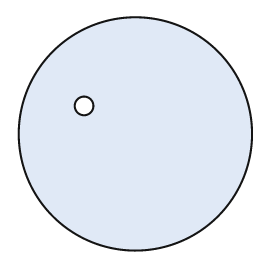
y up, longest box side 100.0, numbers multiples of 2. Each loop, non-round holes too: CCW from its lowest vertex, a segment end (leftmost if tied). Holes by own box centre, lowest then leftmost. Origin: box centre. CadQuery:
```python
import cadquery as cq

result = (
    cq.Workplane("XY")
    .moveTo(0.0, 0.0)
    .circle(50.0)
    .moveTo(-22.0, 12.0)
    .circle(4.0)
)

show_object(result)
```